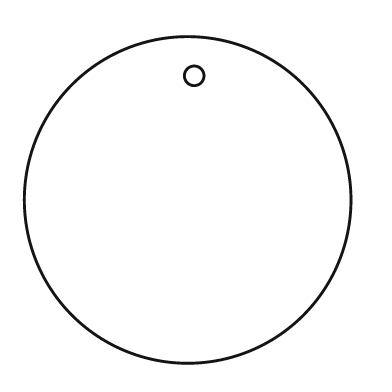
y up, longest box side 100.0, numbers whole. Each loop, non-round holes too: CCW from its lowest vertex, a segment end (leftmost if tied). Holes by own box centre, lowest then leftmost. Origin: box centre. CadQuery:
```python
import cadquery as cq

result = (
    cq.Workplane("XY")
    .moveTo(0.0, 0.0)
    .circle(50.0)
    .moveTo(2.0, 38.0)
    .circle(3.0)
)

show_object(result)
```